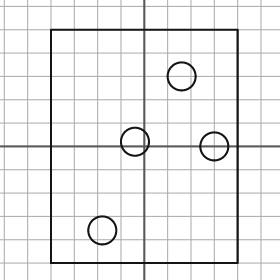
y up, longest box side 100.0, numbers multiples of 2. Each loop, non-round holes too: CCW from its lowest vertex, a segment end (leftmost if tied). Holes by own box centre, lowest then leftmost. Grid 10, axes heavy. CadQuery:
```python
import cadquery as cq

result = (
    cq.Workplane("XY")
    .moveTo(-40.0, -50.0)
    .lineTo(40.0, -50.0)
    .lineTo(40.0, 50.0)
    .lineTo(-40.0, 50.0)
    .close()
    .moveTo(-18.0, -36.0)
    .circle(6.0)
    .moveTo(30.0, 0.0)
    .circle(6.0)
    .moveTo(-4.0, 2.0)
    .circle(6.0)
    .moveTo(16.0, 30.0)
    .circle(6.0)
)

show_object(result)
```